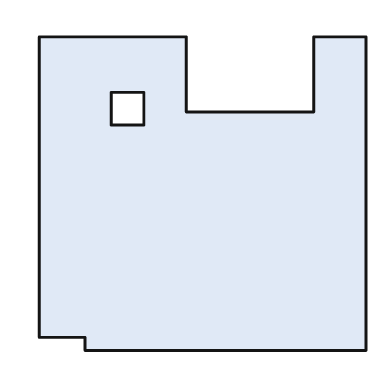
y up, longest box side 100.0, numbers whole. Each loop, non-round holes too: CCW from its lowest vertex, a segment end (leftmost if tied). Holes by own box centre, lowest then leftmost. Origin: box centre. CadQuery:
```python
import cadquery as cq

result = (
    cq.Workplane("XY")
    .moveTo(-36.0, -48.0)
    .lineTo(50.0, -48.0)
    .lineTo(50.0, 48.0)
    .lineTo(34.0, 48.0)
    .lineTo(34.0, 25.0)
    .lineTo(-5.0, 25.0)
    .lineTo(-5.0, 48.0)
    .lineTo(-50.0, 48.0)
    .lineTo(-50.0, -44.0)
    .lineTo(-36.0, -44.0)
    .close()
    .moveTo(-28.0, 21.0)
    .lineTo(-18.0, 21.0)
    .lineTo(-18.0, 31.0)
    .lineTo(-28.0, 31.0)
    .close()
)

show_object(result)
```